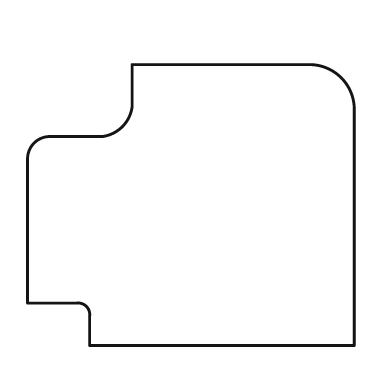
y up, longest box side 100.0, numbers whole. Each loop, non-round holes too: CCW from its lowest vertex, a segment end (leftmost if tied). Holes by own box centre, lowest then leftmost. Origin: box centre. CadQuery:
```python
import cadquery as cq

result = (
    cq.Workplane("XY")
    .moveTo(-31.0, -43.0)
    .lineTo(50.0, -43.0)
    .lineTo(50.0, 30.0)
    .threePointArc((46.0, 39.0), (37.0, 43.0))
    .lineTo(-18.0, 43.0)
    .lineTo(-18.0, 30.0)
    .threePointArc((-21.0, 24.0), (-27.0, 21.0))
    .lineTo(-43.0, 21.0)
    .threePointArc((-48.0, 19.0), (-50.0, 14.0))
    .lineTo(-50.0, -30.0)
    .lineTo(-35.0, -30.0)
    .threePointArc((-32.0, -31.0), (-31.0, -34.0))
    .close()
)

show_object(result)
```